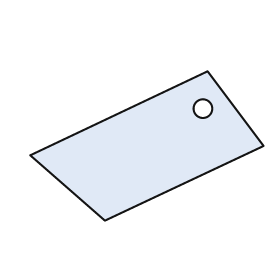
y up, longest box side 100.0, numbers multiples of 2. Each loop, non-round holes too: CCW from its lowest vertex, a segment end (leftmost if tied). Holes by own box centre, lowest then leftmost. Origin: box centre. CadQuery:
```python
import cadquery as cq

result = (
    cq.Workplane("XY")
    .moveTo(-18.0, -32.0)
    .lineTo(50.0, 0.0)
    .lineTo(26.0, 32.0)
    .lineTo(-50.0, -4.0)
    .close()
    .moveTo(24.0, 16.0)
    .circle(4.0)
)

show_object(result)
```